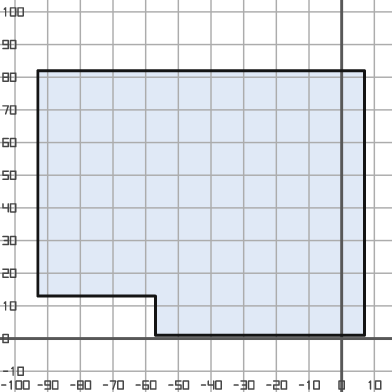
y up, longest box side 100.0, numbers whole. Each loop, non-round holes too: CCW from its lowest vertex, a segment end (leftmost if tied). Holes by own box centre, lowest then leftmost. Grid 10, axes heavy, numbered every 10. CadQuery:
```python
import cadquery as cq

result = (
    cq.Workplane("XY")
    .moveTo(-57.0, 1.0)
    .lineTo(7.0, 1.0)
    .lineTo(7.0, 82.0)
    .lineTo(-93.0, 82.0)
    .lineTo(-93.0, 13.0)
    .lineTo(-57.0, 13.0)
    .close()
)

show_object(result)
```